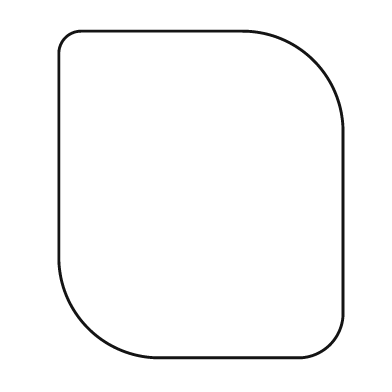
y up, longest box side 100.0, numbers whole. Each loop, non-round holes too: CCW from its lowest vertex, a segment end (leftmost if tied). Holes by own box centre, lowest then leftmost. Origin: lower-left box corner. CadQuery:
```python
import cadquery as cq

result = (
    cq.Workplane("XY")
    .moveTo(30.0, 0.0)
    .lineTo(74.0, 0.0)
    .threePointArc((83.0, 4.0), (87.0, 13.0))
    .lineTo(87.0, 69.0)
    .threePointArc((78.0, 91.0), (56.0, 100.0))
    .lineTo(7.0, 100.0)
    .threePointArc((2.0, 98.0), (0.0, 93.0))
    .lineTo(0.0, 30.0)
    .threePointArc((9.0, 9.0), (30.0, 0.0))
    .close()
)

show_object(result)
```